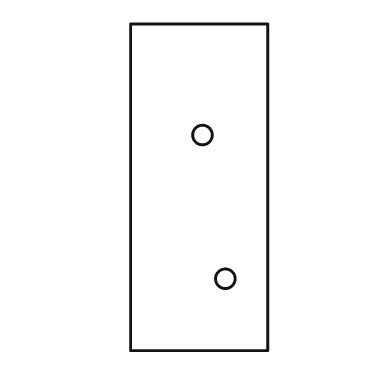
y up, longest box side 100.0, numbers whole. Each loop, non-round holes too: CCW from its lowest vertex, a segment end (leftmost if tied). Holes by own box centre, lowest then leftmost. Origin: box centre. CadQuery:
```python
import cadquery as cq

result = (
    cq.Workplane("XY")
    .moveTo(-21.0, -50.0)
    .lineTo(21.0, -50.0)
    .lineTo(21.0, 50.0)
    .lineTo(-21.0, 50.0)
    .close()
    .moveTo(8.0, -28.0)
    .circle(3.0)
    .moveTo(1.0, 16.0)
    .circle(3.0)
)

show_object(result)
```